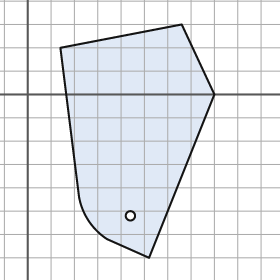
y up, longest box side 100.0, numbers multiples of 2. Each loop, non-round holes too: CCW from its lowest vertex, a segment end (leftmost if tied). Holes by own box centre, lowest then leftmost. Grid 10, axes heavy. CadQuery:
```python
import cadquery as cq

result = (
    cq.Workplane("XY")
    .moveTo(52.0, -70.0)
    .lineTo(80.0, 0.0)
    .lineTo(66.0, 30.0)
    .lineTo(14.0, 20.0)
    .lineTo(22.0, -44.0)
    .threePointArc((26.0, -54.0), (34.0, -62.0))
    .close()
    .moveTo(44.0, -52.0)
    .circle(2.0)
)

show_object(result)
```